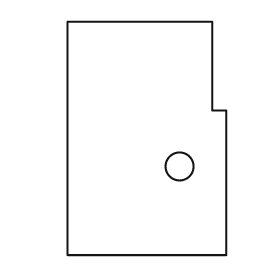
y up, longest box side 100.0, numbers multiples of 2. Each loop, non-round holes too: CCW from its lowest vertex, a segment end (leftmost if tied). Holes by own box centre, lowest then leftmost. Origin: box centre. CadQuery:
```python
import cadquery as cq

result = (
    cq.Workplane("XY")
    .moveTo(-34.0, -50.0)
    .lineTo(34.0, -50.0)
    .lineTo(34.0, 12.0)
    .lineTo(28.0, 12.0)
    .lineTo(28.0, 50.0)
    .lineTo(-34.0, 50.0)
    .close()
    .moveTo(14.0, -12.0)
    .circle(6.0)
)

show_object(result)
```